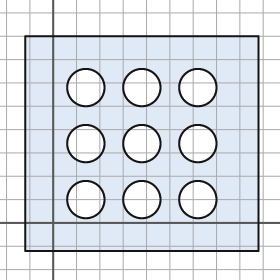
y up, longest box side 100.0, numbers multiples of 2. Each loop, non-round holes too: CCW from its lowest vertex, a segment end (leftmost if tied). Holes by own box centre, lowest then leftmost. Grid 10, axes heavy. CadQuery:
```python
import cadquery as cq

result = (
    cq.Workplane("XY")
    .moveTo(-12.0, -12.0)
    .lineTo(88.0, -12.0)
    .lineTo(88.0, 80.0)
    .lineTo(-12.0, 80.0)
    .close()
    .moveTo(14.0, 10.0)
    .circle(8.0)
    .moveTo(38.0, 10.0)
    .circle(8.0)
    .moveTo(62.0, 10.0)
    .circle(8.0)
    .moveTo(14.0, 34.0)
    .circle(8.0)
    .moveTo(38.0, 34.0)
    .circle(8.0)
    .moveTo(62.0, 34.0)
    .circle(8.0)
    .moveTo(14.0, 58.0)
    .circle(8.0)
    .moveTo(38.0, 58.0)
    .circle(8.0)
    .moveTo(62.0, 58.0)
    .circle(8.0)
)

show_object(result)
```